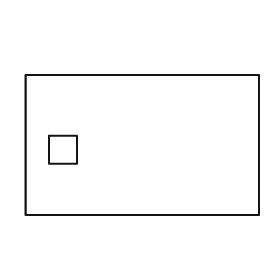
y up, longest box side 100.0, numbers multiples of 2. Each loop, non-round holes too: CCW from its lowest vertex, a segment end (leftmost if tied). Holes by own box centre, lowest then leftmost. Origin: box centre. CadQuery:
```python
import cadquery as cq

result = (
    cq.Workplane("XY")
    .moveTo(-50.0, -30.0)
    .lineTo(50.0, -30.0)
    .lineTo(50.0, 30.0)
    .lineTo(-50.0, 30.0)
    .close()
    .moveTo(-40.0, -8.0)
    .lineTo(-28.0, -8.0)
    .lineTo(-28.0, 4.0)
    .lineTo(-40.0, 4.0)
    .close()
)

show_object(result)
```